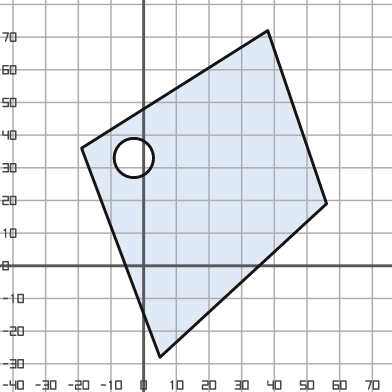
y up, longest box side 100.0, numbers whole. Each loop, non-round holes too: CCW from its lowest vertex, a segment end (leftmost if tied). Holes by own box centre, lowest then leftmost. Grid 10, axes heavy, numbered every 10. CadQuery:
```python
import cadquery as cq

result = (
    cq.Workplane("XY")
    .moveTo(5.0, -28.0)
    .lineTo(56.0, 19.0)
    .lineTo(38.0, 72.0)
    .lineTo(-19.0, 36.0)
    .close()
    .moveTo(-3.0, 33.0)
    .circle(6.0)
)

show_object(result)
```